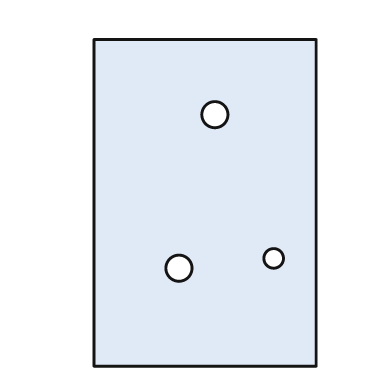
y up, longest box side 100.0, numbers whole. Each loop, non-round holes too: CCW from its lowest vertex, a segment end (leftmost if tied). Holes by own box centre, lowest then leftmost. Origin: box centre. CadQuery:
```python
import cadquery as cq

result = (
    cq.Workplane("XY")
    .moveTo(-34.0, -50.0)
    .lineTo(34.0, -50.0)
    .lineTo(34.0, 50.0)
    .lineTo(-34.0, 50.0)
    .close()
    .moveTo(-8.0, -20.0)
    .circle(4.0)
    .moveTo(21.0, -17.0)
    .circle(3.0)
    .moveTo(3.0, 27.0)
    .circle(4.0)
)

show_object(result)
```